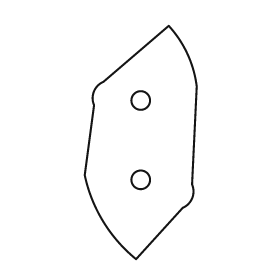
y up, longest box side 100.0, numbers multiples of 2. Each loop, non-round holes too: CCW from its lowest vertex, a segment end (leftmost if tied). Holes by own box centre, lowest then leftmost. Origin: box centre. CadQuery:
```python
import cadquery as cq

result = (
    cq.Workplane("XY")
    .moveTo(-2.0, -50.0)
    .lineTo(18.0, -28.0)
    .threePointArc((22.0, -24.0), (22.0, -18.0))
    .lineTo(24.0, 24.0)
    .threePointArc((20.0, 38.0), (12.0, 50.0))
    .lineTo(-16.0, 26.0)
    .threePointArc((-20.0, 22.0), (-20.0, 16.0))
    .lineTo(-24.0, -14.0)
    .threePointArc((-16.0, -34.0), (-2.0, -50.0))
    .close()
    .moveTo(0.0, -16.0)
    .circle(4.0)
    .moveTo(0.0, 18.0)
    .circle(4.0)
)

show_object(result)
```